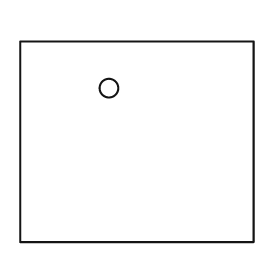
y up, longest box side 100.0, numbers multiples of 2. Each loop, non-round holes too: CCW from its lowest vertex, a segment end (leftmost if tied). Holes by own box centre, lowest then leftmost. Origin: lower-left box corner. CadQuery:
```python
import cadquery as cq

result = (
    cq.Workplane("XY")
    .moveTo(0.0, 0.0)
    .lineTo(100.0, 0.0)
    .lineTo(100.0, 86.0)
    .lineTo(0.0, 86.0)
    .close()
    .moveTo(38.0, 66.0)
    .circle(4.0)
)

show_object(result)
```